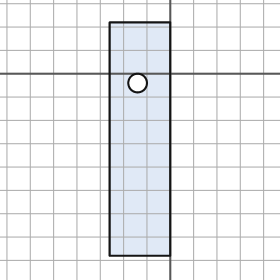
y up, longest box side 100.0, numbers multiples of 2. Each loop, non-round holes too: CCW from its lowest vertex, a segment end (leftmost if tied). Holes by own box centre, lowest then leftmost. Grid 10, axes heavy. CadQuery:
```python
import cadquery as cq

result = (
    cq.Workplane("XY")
    .moveTo(-26.0, -78.0)
    .lineTo(0.0, -78.0)
    .lineTo(0.0, 22.0)
    .lineTo(-26.0, 22.0)
    .close()
    .moveTo(-14.0, -4.0)
    .circle(4.0)
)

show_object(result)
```